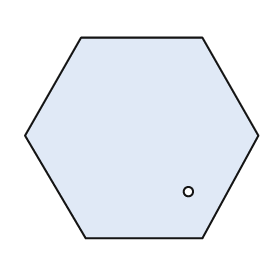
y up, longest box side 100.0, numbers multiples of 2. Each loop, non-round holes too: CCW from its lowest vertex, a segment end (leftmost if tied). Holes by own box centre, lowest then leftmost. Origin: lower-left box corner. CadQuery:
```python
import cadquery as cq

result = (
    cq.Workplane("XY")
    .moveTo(26.0, 0.0)
    .lineTo(76.0, 0.0)
    .lineTo(100.0, 44.0)
    .lineTo(76.0, 86.0)
    .lineTo(24.0, 86.0)
    .lineTo(0.0, 44.0)
    .close()
    .moveTo(70.0, 20.0)
    .circle(2.0)
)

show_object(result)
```